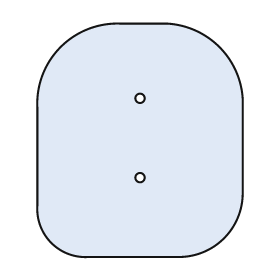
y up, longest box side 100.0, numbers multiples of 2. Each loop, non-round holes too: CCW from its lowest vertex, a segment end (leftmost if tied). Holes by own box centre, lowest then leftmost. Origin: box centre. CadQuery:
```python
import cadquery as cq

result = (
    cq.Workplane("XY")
    .moveTo(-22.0, -50.0)
    .lineTo(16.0, -50.0)
    .threePointArc((36.0, -42.0), (44.0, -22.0))
    .lineTo(44.0, 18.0)
    .threePointArc((34.0, 40.0), (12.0, 50.0))
    .lineTo(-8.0, 50.0)
    .threePointArc((-34.0, 40.0), (-44.0, 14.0))
    .lineTo(-44.0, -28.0)
    .threePointArc((-38.0, -44.0), (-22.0, -50.0))
    .close()
    .moveTo(0.0, -16.0)
    .circle(2.0)
    .moveTo(0.0, 18.0)
    .circle(2.0)
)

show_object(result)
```